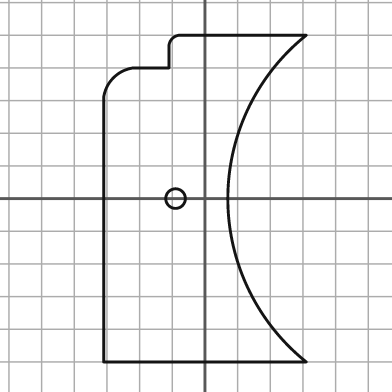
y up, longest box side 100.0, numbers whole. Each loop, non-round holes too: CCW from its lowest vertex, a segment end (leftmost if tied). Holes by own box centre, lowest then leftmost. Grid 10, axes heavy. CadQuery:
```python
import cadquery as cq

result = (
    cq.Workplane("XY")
    .moveTo(-31.0, -50.0)
    .lineTo(31.0, -50.0)
    .threePointArc((7.0, 0.0), (31.0, 50.0))
    .lineTo(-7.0, 50.0)
    .threePointArc((-10.0, 49.0), (-11.0, 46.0))
    .lineTo(-11.0, 40.0)
    .lineTo(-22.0, 40.0)
    .threePointArc((-28.0, 37.0), (-31.0, 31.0))
    .close()
    .moveTo(-9.0, 0.0)
    .circle(3.0)
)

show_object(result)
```